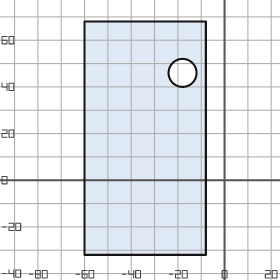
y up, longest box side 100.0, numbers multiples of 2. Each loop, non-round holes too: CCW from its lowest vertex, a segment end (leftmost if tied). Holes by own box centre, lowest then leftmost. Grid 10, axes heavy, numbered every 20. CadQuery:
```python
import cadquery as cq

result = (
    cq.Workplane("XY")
    .moveTo(-60.0, -32.0)
    .lineTo(-8.0, -32.0)
    .lineTo(-8.0, 68.0)
    .lineTo(-60.0, 68.0)
    .close()
    .moveTo(-18.0, 46.0)
    .circle(6.0)
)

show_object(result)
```